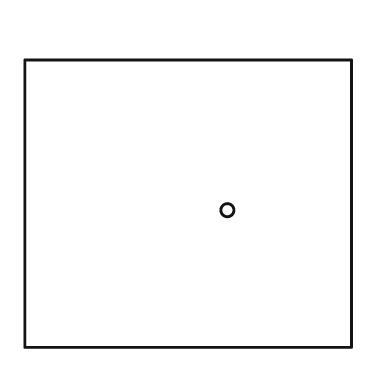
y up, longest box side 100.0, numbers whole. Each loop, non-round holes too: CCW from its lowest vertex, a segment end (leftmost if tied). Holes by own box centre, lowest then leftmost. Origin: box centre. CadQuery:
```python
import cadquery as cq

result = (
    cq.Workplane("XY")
    .moveTo(-50.0, -44.0)
    .lineTo(50.0, -44.0)
    .lineTo(50.0, 44.0)
    .lineTo(-50.0, 44.0)
    .close()
    .moveTo(12.0, -2.0)
    .circle(2.0)
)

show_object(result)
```